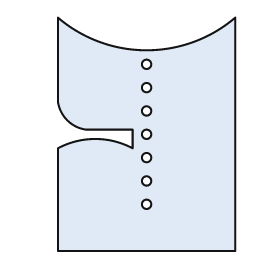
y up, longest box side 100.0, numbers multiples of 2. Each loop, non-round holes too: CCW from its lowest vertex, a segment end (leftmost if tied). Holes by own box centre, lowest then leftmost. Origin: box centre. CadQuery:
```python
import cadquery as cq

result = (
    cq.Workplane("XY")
    .moveTo(-38.0, -50.0)
    .lineTo(38.0, -50.0)
    .lineTo(38.0, 50.0)
    .threePointArc((0.0, 36.0), (-38.0, 50.0))
    .lineTo(-38.0, 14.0)
    .threePointArc((-34.0, 6.0), (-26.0, 2.0))
    .lineTo(-6.0, 2.0)
    .lineTo(-6.0, -6.0)
    .threePointArc((-22.0, -2.0), (-38.0, -6.0))
    .close()
    .moveTo(0.0, -30.0)
    .circle(2.0)
    .moveTo(0.0, -20.0)
    .circle(2.0)
    .moveTo(0.0, -10.0)
    .circle(2.0)
    .moveTo(0.0, 0.0)
    .circle(2.0)
    .moveTo(0.0, 10.0)
    .circle(2.0)
    .moveTo(0.0, 20.0)
    .circle(2.0)
    .moveTo(0.0, 30.0)
    .circle(2.0)
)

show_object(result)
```